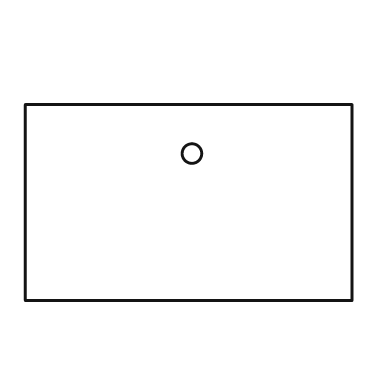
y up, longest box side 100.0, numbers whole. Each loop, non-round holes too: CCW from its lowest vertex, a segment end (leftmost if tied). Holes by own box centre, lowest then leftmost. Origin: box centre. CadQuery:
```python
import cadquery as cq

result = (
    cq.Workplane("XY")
    .moveTo(-50.0, -30.0)
    .lineTo(50.0, -30.0)
    .lineTo(50.0, 30.0)
    .lineTo(-50.0, 30.0)
    .close()
    .moveTo(1.0, 15.0)
    .circle(3.0)
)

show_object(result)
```